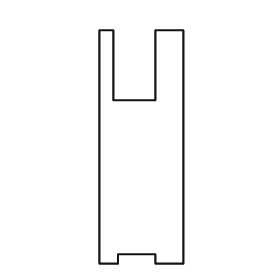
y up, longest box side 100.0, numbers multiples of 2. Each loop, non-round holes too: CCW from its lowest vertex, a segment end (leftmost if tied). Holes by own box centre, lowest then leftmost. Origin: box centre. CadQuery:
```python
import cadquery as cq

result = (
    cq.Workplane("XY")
    .moveTo(-18.0, -50.0)
    .lineTo(-10.0, -50.0)
    .lineTo(-10.0, -46.0)
    .lineTo(6.0, -46.0)
    .lineTo(6.0, -50.0)
    .lineTo(18.0, -50.0)
    .lineTo(18.0, 50.0)
    .lineTo(6.0, 50.0)
    .lineTo(6.0, 20.0)
    .lineTo(-12.0, 20.0)
    .lineTo(-12.0, 50.0)
    .lineTo(-18.0, 50.0)
    .close()
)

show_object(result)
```